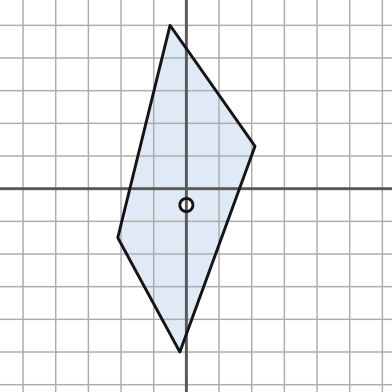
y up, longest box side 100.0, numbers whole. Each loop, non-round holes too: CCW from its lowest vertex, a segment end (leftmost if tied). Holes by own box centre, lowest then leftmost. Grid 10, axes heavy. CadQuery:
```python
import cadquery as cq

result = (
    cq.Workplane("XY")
    .moveTo(-2.0, -50.0)
    .lineTo(21.0, 13.0)
    .lineTo(-5.0, 50.0)
    .lineTo(-21.0, -15.0)
    .close()
    .moveTo(0.0, -5.0)
    .circle(2.0)
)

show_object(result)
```